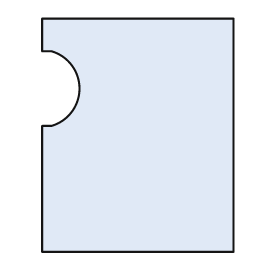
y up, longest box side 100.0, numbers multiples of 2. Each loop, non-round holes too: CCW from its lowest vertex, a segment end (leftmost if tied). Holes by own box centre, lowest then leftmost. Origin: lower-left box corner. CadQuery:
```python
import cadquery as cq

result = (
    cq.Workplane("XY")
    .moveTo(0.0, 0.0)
    .lineTo(82.0, 0.0)
    .lineTo(82.0, 100.0)
    .lineTo(0.0, 100.0)
    .lineTo(0.0, 86.0)
    .lineTo(4.0, 86.0)
    .threePointArc((16.0, 70.0), (4.0, 54.0))
    .lineTo(0.0, 54.0)
    .close()
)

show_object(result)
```